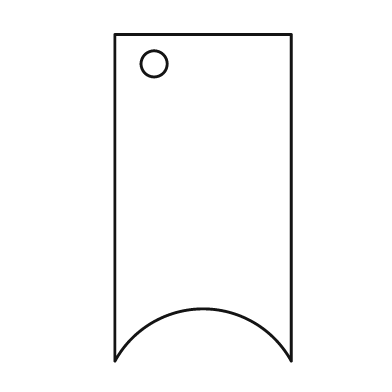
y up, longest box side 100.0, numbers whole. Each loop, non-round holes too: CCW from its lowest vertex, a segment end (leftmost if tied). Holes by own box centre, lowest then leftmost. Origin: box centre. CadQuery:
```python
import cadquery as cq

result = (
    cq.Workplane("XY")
    .moveTo(-27.0, -50.0)
    .threePointArc((0.0, -34.0), (27.0, -50.0))
    .lineTo(27.0, 50.0)
    .lineTo(-27.0, 50.0)
    .close()
    .moveTo(-15.0, 41.0)
    .circle(4.0)
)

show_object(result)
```